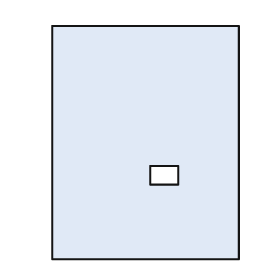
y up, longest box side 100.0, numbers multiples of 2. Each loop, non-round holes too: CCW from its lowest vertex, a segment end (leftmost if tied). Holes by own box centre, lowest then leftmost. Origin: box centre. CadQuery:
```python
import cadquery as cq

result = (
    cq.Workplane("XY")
    .moveTo(-40.0, -50.0)
    .lineTo(40.0, -50.0)
    .lineTo(40.0, 50.0)
    .lineTo(-40.0, 50.0)
    .close()
    .moveTo(2.0, -18.0)
    .lineTo(14.0, -18.0)
    .lineTo(14.0, -10.0)
    .lineTo(2.0, -10.0)
    .close()
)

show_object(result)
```